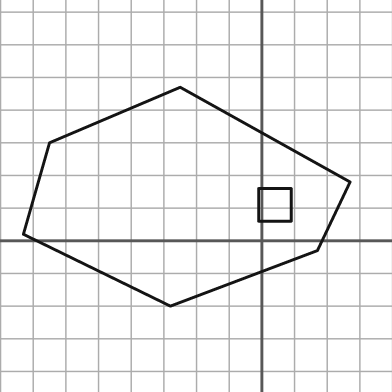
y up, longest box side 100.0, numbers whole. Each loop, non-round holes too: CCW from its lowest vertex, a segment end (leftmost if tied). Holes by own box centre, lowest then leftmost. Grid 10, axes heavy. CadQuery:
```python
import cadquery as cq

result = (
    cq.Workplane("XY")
    .moveTo(-28.0, -20.0)
    .lineTo(17.0, -3.0)
    .lineTo(27.0, 18.0)
    .lineTo(-25.0, 47.0)
    .lineTo(-65.0, 30.0)
    .lineTo(-73.0, 2.0)
    .close()
    .moveTo(-1.0, 6.0)
    .lineTo(9.0, 6.0)
    .lineTo(9.0, 16.0)
    .lineTo(-1.0, 16.0)
    .close()
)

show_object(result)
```